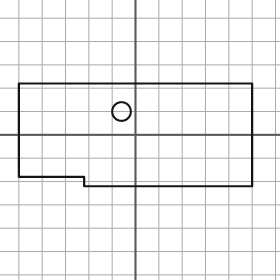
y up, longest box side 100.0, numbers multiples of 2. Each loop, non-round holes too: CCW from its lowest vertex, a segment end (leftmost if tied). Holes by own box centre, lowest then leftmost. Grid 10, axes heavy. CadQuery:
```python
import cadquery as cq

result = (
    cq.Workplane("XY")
    .moveTo(-22.0, -22.0)
    .lineTo(50.0, -22.0)
    .lineTo(50.0, 22.0)
    .lineTo(-50.0, 22.0)
    .lineTo(-50.0, -18.0)
    .lineTo(-22.0, -18.0)
    .close()
    .moveTo(-6.0, 10.0)
    .circle(4.0)
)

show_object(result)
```